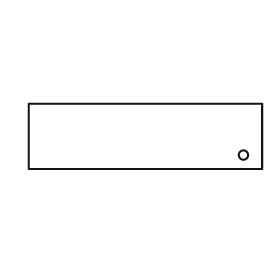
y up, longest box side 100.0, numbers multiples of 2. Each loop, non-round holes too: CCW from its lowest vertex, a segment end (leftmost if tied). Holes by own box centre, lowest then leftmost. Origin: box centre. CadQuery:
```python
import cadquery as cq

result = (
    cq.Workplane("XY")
    .moveTo(-50.0, -14.0)
    .lineTo(50.0, -14.0)
    .lineTo(50.0, 14.0)
    .lineTo(-50.0, 14.0)
    .close()
    .moveTo(42.0, -8.0)
    .circle(2.0)
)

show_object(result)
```